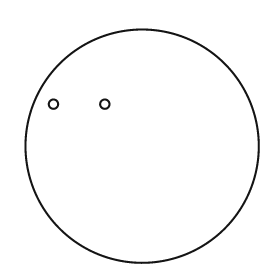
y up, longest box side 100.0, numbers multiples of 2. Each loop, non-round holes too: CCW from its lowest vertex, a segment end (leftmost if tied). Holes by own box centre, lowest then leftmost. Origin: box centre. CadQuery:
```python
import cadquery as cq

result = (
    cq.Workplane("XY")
    .moveTo(0.0, 0.0)
    .circle(50.0)
    .moveTo(-38.0, 18.0)
    .circle(2.0)
    .moveTo(-16.0, 18.0)
    .circle(2.0)
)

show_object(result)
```